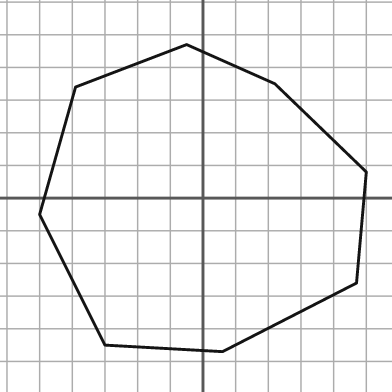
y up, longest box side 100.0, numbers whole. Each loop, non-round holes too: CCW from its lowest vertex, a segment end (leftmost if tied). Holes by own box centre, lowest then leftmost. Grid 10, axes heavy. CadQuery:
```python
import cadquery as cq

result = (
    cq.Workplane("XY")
    .moveTo(6.0, -47.0)
    .lineTo(47.0, -26.0)
    .lineTo(50.0, 8.0)
    .lineTo(22.0, 35.0)
    .lineTo(-5.0, 47.0)
    .lineTo(-39.0, 34.0)
    .lineTo(-50.0, -5.0)
    .lineTo(-30.0, -45.0)
    .close()
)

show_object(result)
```